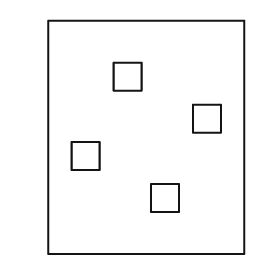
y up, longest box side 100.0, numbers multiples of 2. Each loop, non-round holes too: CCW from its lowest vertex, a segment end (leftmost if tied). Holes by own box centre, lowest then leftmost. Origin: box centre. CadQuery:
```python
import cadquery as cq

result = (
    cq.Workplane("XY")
    .moveTo(-42.0, -50.0)
    .lineTo(42.0, -50.0)
    .lineTo(42.0, 50.0)
    .lineTo(-42.0, 50.0)
    .close()
    .moveTo(2.0, -32.0)
    .lineTo(14.0, -32.0)
    .lineTo(14.0, -20.0)
    .lineTo(2.0, -20.0)
    .close()
    .moveTo(-32.0, -14.0)
    .lineTo(-20.0, -14.0)
    .lineTo(-20.0, -2.0)
    .lineTo(-32.0, -2.0)
    .close()
    .moveTo(20.0, 2.0)
    .lineTo(32.0, 2.0)
    .lineTo(32.0, 14.0)
    .lineTo(20.0, 14.0)
    .close()
    .moveTo(-14.0, 20.0)
    .lineTo(-2.0, 20.0)
    .lineTo(-2.0, 32.0)
    .lineTo(-14.0, 32.0)
    .close()
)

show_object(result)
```